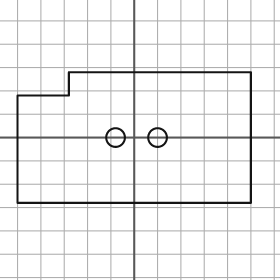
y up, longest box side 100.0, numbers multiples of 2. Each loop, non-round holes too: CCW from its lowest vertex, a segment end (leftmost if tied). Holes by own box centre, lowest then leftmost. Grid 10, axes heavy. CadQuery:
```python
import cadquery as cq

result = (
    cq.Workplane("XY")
    .moveTo(-50.0, -28.0)
    .lineTo(50.0, -28.0)
    .lineTo(50.0, 28.0)
    .lineTo(-28.0, 28.0)
    .lineTo(-28.0, 18.0)
    .lineTo(-50.0, 18.0)
    .close()
    .moveTo(-8.0, 0.0)
    .circle(4.0)
    .moveTo(10.0, 0.0)
    .circle(4.0)
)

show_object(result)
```